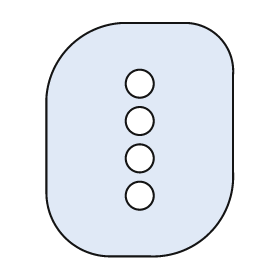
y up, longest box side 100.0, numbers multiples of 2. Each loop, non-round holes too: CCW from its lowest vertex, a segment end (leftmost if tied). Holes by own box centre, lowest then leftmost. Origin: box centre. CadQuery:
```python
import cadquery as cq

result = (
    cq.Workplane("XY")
    .moveTo(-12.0, -50.0)
    .lineTo(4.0, -50.0)
    .threePointArc((30.0, -40.0), (40.0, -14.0))
    .lineTo(40.0, 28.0)
    .threePointArc((34.0, 44.0), (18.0, 50.0))
    .lineTo(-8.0, 50.0)
    .threePointArc((-30.0, 40.0), (-40.0, 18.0))
    .lineTo(-40.0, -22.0)
    .threePointArc((-32.0, -42.0), (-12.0, -50.0))
    .close()
    .moveTo(0.0, -24.0)
    .circle(6.0)
    .moveTo(0.0, -8.0)
    .circle(6.0)
    .moveTo(0.0, 8.0)
    .circle(6.0)
    .moveTo(0.0, 24.0)
    .circle(6.0)
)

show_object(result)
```